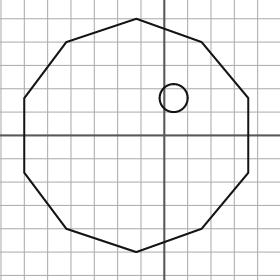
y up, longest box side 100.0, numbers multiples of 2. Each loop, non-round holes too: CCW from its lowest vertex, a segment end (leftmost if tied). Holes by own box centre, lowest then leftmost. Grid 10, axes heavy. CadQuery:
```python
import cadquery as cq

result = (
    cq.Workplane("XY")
    .moveTo(-12.0, -50.0)
    .lineTo(16.0, -40.0)
    .lineTo(36.0, -16.0)
    .lineTo(36.0, 16.0)
    .lineTo(16.0, 40.0)
    .lineTo(-12.0, 50.0)
    .lineTo(-42.0, 40.0)
    .lineTo(-60.0, 16.0)
    .lineTo(-60.0, -16.0)
    .lineTo(-42.0, -40.0)
    .close()
    .moveTo(4.0, 16.0)
    .circle(6.0)
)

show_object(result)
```